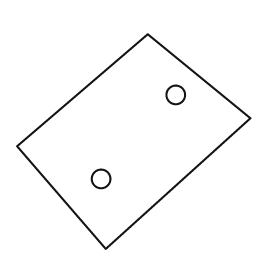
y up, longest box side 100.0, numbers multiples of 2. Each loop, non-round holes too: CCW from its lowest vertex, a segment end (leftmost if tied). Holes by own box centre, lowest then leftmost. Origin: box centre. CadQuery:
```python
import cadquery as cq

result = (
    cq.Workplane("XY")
    .moveTo(-12.0, -46.0)
    .lineTo(50.0, 10.0)
    .lineTo(6.0, 46.0)
    .lineTo(-50.0, -2.0)
    .close()
    .moveTo(-14.0, -16.0)
    .circle(4.0)
    .moveTo(18.0, 20.0)
    .circle(4.0)
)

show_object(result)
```